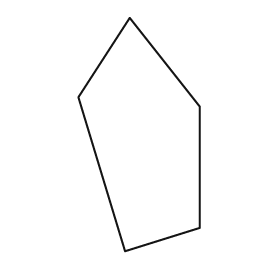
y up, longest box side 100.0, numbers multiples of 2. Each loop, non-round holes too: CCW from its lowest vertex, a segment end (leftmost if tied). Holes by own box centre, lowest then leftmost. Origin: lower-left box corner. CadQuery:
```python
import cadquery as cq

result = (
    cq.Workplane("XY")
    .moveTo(20.0, 0.0)
    .lineTo(52.0, 10.0)
    .lineTo(52.0, 62.0)
    .lineTo(22.0, 100.0)
    .lineTo(0.0, 66.0)
    .close()
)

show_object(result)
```